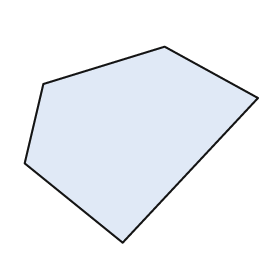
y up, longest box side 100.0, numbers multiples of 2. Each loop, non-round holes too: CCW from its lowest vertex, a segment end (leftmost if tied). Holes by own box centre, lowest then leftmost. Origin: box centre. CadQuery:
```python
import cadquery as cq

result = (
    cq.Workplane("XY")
    .moveTo(-8.0, -42.0)
    .lineTo(50.0, 20.0)
    .lineTo(10.0, 42.0)
    .lineTo(-42.0, 26.0)
    .lineTo(-50.0, -8.0)
    .close()
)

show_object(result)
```